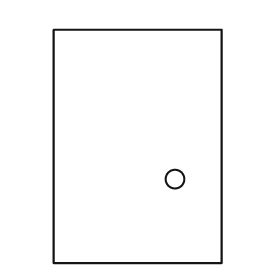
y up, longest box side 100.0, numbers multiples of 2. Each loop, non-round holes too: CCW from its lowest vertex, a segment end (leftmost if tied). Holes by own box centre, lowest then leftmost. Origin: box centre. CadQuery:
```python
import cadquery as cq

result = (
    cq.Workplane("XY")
    .moveTo(-36.0, -50.0)
    .lineTo(36.0, -50.0)
    .lineTo(36.0, 50.0)
    .lineTo(-36.0, 50.0)
    .close()
    .moveTo(16.0, -14.0)
    .circle(4.0)
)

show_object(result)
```